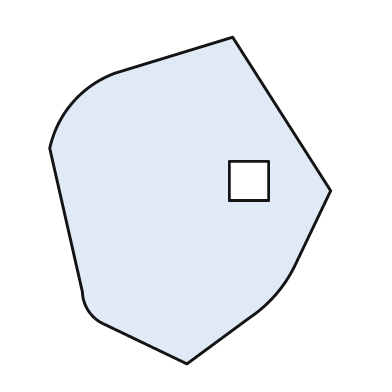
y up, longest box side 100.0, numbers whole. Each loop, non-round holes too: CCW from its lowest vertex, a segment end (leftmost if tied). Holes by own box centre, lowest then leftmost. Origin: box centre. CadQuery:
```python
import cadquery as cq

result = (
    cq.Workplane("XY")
    .moveTo(-1.0, -50.0)
    .lineTo(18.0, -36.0)
    .threePointArc((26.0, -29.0), (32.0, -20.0))
    .lineTo(43.0, 3.0)
    .lineTo(13.0, 50.0)
    .lineTo(-23.0, 39.0)
    .threePointArc((-36.0, 30.0), (-43.0, 16.0))
    .lineTo(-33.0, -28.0)
    .threePointArc((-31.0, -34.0), (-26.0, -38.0))
    .close()
    .moveTo(12.0, 0.0)
    .lineTo(24.0, 0.0)
    .lineTo(24.0, 12.0)
    .lineTo(12.0, 12.0)
    .close()
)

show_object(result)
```